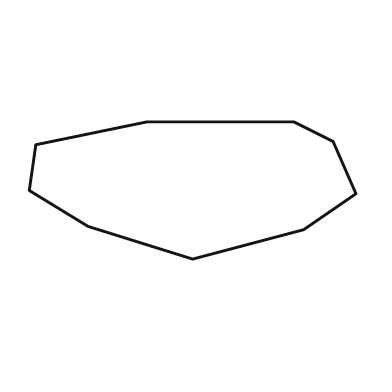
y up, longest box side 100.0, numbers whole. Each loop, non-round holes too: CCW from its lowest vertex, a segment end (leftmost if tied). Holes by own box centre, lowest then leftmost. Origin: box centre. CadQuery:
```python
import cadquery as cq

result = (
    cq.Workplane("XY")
    .moveTo(0.0, -21.0)
    .lineTo(34.0, -12.0)
    .lineTo(50.0, -1.0)
    .lineTo(43.0, 15.0)
    .lineTo(31.0, 21.0)
    .lineTo(-14.0, 21.0)
    .lineTo(-48.0, 14.0)
    .lineTo(-50.0, 0.0)
    .lineTo(-32.0, -11.0)
    .close()
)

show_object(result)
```